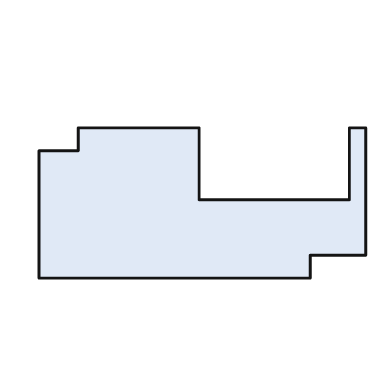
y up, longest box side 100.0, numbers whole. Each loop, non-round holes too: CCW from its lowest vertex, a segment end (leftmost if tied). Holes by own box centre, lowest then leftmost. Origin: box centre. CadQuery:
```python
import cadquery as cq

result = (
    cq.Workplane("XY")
    .moveTo(-50.0, -23.0)
    .lineTo(33.0, -23.0)
    .lineTo(33.0, -16.0)
    .lineTo(50.0, -16.0)
    .lineTo(50.0, 23.0)
    .lineTo(45.0, 23.0)
    .lineTo(45.0, 1.0)
    .lineTo(-1.0, 1.0)
    .lineTo(-1.0, 23.0)
    .lineTo(-38.0, 23.0)
    .lineTo(-38.0, 16.0)
    .lineTo(-50.0, 16.0)
    .close()
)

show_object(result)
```